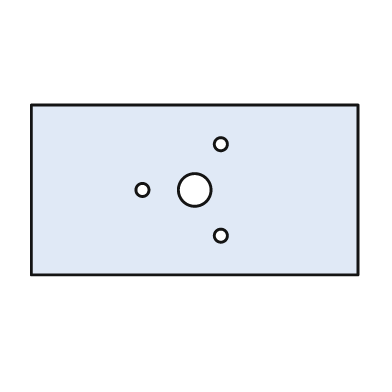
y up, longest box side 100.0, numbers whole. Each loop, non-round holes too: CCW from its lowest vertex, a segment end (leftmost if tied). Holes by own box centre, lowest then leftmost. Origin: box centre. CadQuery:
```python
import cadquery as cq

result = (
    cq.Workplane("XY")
    .moveTo(-50.0, -26.0)
    .lineTo(50.0, -26.0)
    .lineTo(50.0, 26.0)
    .lineTo(-50.0, 26.0)
    .close()
    .moveTo(8.0, -14.0)
    .circle(2.0)
    .moveTo(-16.0, 0.0)
    .circle(2.0)
    .moveTo(0.0, 0.0)
    .circle(5.0)
    .moveTo(8.0, 14.0)
    .circle(2.0)
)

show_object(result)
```